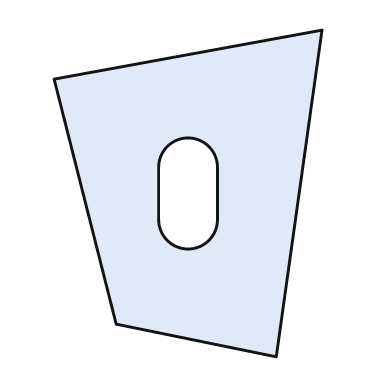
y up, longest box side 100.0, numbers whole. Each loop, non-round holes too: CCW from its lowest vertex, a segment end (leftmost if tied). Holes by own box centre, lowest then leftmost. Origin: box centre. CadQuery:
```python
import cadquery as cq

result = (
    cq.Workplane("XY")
    .moveTo(27.0, -50.0)
    .lineTo(41.0, 50.0)
    .lineTo(-41.0, 35.0)
    .lineTo(-22.0, -40.0)
    .close()
    .moveTo(-9.0, -8.0)
    .threePointArc((0.0, -17.0), (9.0, -8.0))
    .lineTo(9.0, 8.0)
    .threePointArc((0.0, 17.0), (-9.0, 8.0))
    .close()
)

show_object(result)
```